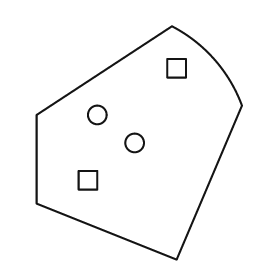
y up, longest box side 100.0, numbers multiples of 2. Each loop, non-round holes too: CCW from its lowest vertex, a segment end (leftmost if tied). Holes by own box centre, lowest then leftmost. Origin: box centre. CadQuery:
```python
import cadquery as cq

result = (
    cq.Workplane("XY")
    .moveTo(16.0, -50.0)
    .lineTo(44.0, 16.0)
    .threePointArc((32.0, 36.0), (14.0, 50.0))
    .lineTo(-44.0, 12.0)
    .lineTo(-44.0, -26.0)
    .close()
    .moveTo(-26.0, -20.0)
    .lineTo(-18.0, -20.0)
    .lineTo(-18.0, -12.0)
    .lineTo(-26.0, -12.0)
    .close()
    .moveTo(-2.0, 0.0)
    .circle(4.0)
    .moveTo(-18.0, 12.0)
    .circle(4.0)
    .moveTo(12.0, 28.0)
    .lineTo(20.0, 28.0)
    .lineTo(20.0, 36.0)
    .lineTo(12.0, 36.0)
    .close()
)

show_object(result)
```